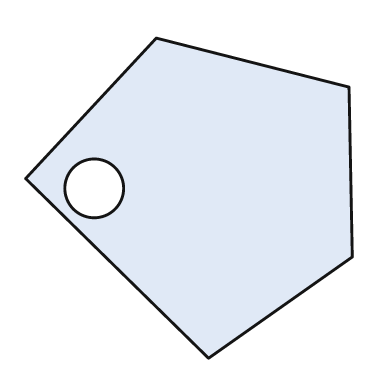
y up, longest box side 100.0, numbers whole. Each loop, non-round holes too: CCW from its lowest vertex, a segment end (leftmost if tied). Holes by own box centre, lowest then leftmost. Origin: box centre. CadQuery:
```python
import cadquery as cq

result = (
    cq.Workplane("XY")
    .moveTo(6.0, -49.0)
    .lineTo(50.0, -18.0)
    .lineTo(49.0, 34.0)
    .lineTo(-10.0, 49.0)
    .lineTo(-50.0, 6.0)
    .close()
    .moveTo(-29.0, 3.0)
    .circle(9.0)
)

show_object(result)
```